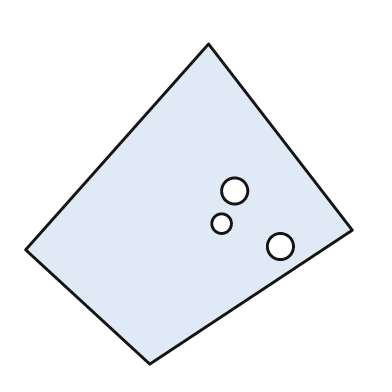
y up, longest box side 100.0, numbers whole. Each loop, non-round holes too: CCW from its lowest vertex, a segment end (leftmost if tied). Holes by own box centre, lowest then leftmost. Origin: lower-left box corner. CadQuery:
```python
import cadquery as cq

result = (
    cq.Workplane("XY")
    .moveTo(38.0, 0.0)
    .lineTo(100.0, 41.0)
    .lineTo(56.0, 98.0)
    .lineTo(0.0, 35.0)
    .close()
    .moveTo(78.0, 36.0)
    .circle(4.0)
    .moveTo(60.0, 43.0)
    .circle(3.0)
    .moveTo(64.0, 53.0)
    .circle(4.0)
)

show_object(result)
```